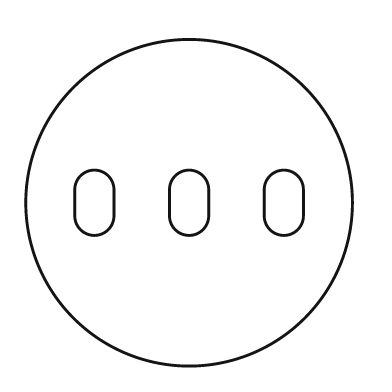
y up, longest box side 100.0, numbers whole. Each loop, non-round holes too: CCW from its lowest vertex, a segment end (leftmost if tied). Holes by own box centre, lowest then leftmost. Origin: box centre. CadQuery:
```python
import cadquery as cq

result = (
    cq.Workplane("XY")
    .moveTo(0.0, 0.0)
    .circle(50.0)
    .moveTo(-35.0, -4.0)
    .threePointArc((-29.0, -10.0), (-23.0, -4.0))
    .lineTo(-23.0, 4.0)
    .threePointArc((-29.0, 10.0), (-35.0, 4.0))
    .close()
    .moveTo(-6.0, -4.0)
    .threePointArc((0.0, -10.0), (6.0, -4.0))
    .lineTo(6.0, 4.0)
    .threePointArc((0.0, 10.0), (-6.0, 4.0))
    .close()
    .moveTo(23.0, -4.0)
    .threePointArc((29.0, -10.0), (35.0, -4.0))
    .lineTo(35.0, 4.0)
    .threePointArc((29.0, 10.0), (23.0, 4.0))
    .close()
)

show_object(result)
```